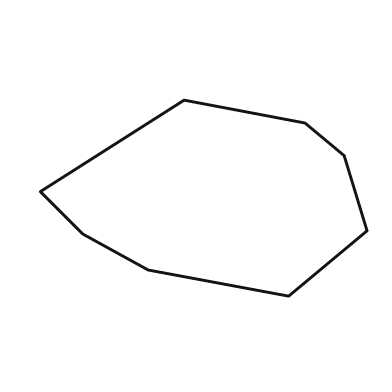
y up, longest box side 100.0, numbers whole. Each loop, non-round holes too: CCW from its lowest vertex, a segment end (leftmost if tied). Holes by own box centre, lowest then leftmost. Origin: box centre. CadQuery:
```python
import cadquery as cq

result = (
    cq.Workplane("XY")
    .moveTo(26.0, -30.0)
    .lineTo(50.0, -10.0)
    .lineTo(43.0, 13.0)
    .lineTo(31.0, 23.0)
    .lineTo(-6.0, 30.0)
    .lineTo(-50.0, 2.0)
    .lineTo(-37.0, -11.0)
    .lineTo(-17.0, -22.0)
    .close()
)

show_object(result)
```